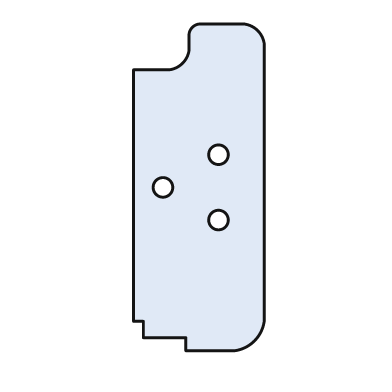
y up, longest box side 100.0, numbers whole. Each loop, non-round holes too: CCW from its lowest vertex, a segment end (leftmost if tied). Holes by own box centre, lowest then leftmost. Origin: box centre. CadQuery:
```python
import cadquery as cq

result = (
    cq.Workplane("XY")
    .moveTo(-4.0, -50.0)
    .lineTo(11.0, -50.0)
    .threePointArc((17.0, -47.0), (20.0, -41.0))
    .lineTo(20.0, 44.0)
    .threePointArc((18.0, 48.0), (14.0, 50.0))
    .lineTo(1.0, 50.0)
    .threePointArc((-2.0, 49.0), (-3.0, 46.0))
    .lineTo(-3.0, 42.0)
    .threePointArc((-5.0, 38.0), (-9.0, 36.0))
    .lineTo(-20.0, 36.0)
    .lineTo(-20.0, -41.0)
    .lineTo(-17.0, -41.0)
    .lineTo(-17.0, -46.0)
    .lineTo(-4.0, -46.0)
    .close()
    .moveTo(6.0, -10.0)
    .circle(3.0)
    .moveTo(-11.0, 0.0)
    .circle(3.0)
    .moveTo(6.0, 10.0)
    .circle(3.0)
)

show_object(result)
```